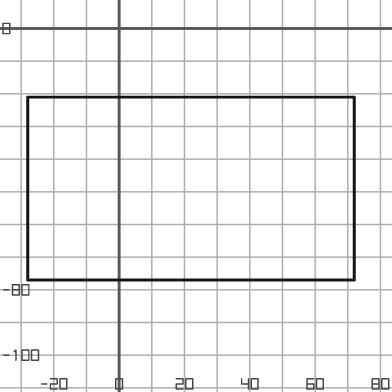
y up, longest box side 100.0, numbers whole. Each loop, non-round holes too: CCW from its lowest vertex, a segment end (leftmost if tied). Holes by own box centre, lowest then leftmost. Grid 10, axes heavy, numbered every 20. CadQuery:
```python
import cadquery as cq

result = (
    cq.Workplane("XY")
    .moveTo(-28.0, -77.0)
    .lineTo(72.0, -77.0)
    .lineTo(72.0, -21.0)
    .lineTo(-28.0, -21.0)
    .close()
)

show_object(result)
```